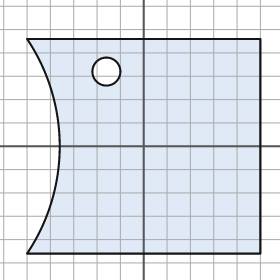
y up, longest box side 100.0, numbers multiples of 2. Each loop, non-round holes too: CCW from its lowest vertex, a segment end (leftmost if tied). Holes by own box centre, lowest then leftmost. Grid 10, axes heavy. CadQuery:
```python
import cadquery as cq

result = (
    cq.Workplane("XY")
    .moveTo(-50.0, -46.0)
    .lineTo(50.0, -46.0)
    .lineTo(50.0, 46.0)
    .lineTo(-50.0, 46.0)
    .threePointArc((-36.0, 0.0), (-50.0, -46.0))
    .close()
    .moveTo(-16.0, 32.0)
    .circle(6.0)
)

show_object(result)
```